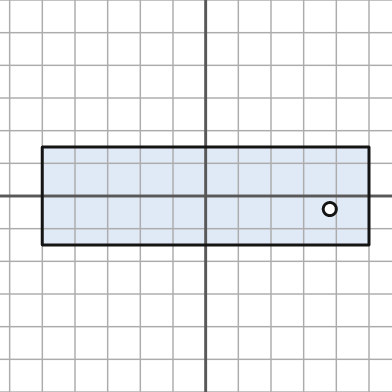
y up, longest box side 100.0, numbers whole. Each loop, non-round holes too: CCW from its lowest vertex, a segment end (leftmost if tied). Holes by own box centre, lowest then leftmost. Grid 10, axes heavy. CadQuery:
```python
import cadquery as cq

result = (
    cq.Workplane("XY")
    .moveTo(-50.0, -15.0)
    .lineTo(50.0, -15.0)
    .lineTo(50.0, 15.0)
    .lineTo(-50.0, 15.0)
    .close()
    .moveTo(38.0, -4.0)
    .circle(2.0)
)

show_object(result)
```